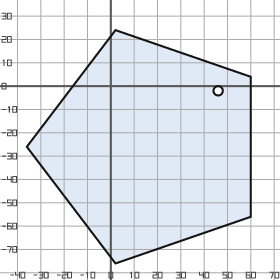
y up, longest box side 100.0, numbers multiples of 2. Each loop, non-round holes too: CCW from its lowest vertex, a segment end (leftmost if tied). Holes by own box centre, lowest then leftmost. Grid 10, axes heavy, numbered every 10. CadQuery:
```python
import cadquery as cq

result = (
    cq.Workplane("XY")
    .moveTo(2.0, -76.0)
    .lineTo(60.0, -56.0)
    .lineTo(60.0, 4.0)
    .lineTo(2.0, 24.0)
    .lineTo(-36.0, -26.0)
    .close()
    .moveTo(46.0, -2.0)
    .circle(2.0)
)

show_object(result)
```